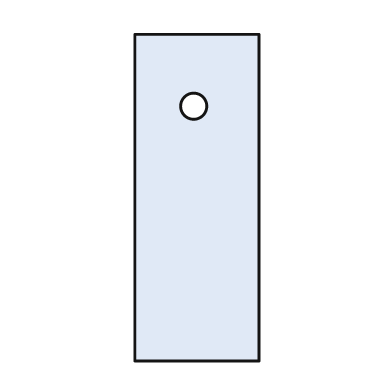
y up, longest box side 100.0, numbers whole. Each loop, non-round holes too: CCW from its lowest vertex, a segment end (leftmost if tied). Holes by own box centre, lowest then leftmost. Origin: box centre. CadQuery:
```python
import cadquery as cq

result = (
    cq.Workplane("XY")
    .moveTo(-19.0, -50.0)
    .lineTo(19.0, -50.0)
    .lineTo(19.0, 50.0)
    .lineTo(-19.0, 50.0)
    .close()
    .moveTo(-1.0, 28.0)
    .circle(4.0)
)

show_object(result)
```